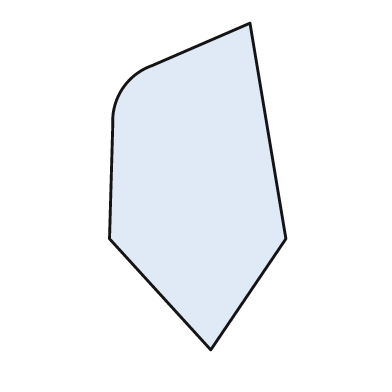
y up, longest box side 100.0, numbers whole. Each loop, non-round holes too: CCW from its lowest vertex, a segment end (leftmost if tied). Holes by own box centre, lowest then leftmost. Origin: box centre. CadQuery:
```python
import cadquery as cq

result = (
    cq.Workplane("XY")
    .moveTo(4.0, -50.0)
    .lineTo(27.0, -16.0)
    .lineTo(16.0, 50.0)
    .lineTo(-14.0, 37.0)
    .threePointArc((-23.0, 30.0), (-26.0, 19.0))
    .lineTo(-27.0, -16.0)
    .close()
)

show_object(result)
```